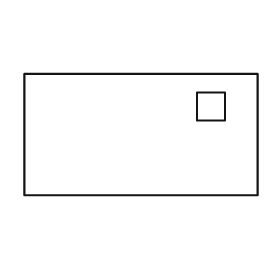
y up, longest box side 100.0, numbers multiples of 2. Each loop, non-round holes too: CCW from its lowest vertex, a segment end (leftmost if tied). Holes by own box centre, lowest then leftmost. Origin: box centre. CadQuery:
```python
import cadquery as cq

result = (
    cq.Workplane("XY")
    .moveTo(-50.0, -26.0)
    .lineTo(50.0, -26.0)
    .lineTo(50.0, 26.0)
    .lineTo(-50.0, 26.0)
    .close()
    .moveTo(24.0, 6.0)
    .lineTo(36.0, 6.0)
    .lineTo(36.0, 18.0)
    .lineTo(24.0, 18.0)
    .close()
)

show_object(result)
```